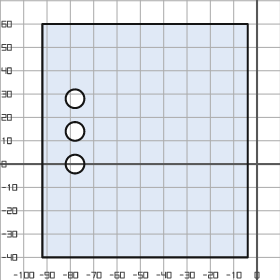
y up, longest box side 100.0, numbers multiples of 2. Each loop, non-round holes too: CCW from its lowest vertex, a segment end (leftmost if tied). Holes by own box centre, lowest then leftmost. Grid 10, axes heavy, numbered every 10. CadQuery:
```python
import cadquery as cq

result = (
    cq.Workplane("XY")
    .moveTo(-92.0, -40.0)
    .lineTo(-4.0, -40.0)
    .lineTo(-4.0, 60.0)
    .lineTo(-92.0, 60.0)
    .close()
    .moveTo(-78.0, 0.0)
    .circle(4.0)
    .moveTo(-78.0, 14.0)
    .circle(4.0)
    .moveTo(-78.0, 28.0)
    .circle(4.0)
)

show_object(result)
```